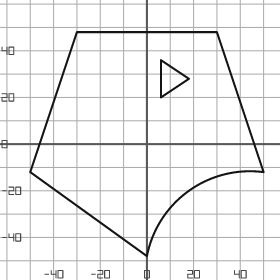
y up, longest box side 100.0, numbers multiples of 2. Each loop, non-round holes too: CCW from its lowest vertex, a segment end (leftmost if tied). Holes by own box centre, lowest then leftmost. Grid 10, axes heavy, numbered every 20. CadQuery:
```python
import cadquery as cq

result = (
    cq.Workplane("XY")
    .moveTo(0.0, -48.0)
    .threePointArc((18.0, -20.0), (50.0, -12.0))
    .lineTo(30.0, 48.0)
    .lineTo(-30.0, 48.0)
    .lineTo(-50.0, -12.0)
    .close()
    .moveTo(6.0, 20.0)
    .lineTo(18.0, 28.0)
    .lineTo(6.0, 36.0)
    .close()
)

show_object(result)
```